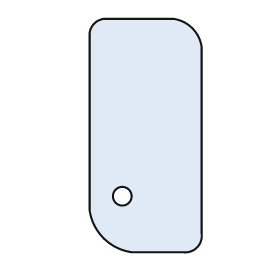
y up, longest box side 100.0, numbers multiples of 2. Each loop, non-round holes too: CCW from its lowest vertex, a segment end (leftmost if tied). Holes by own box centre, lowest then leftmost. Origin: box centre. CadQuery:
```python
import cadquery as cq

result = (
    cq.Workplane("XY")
    .moveTo(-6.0, -50.0)
    .lineTo(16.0, -50.0)
    .threePointArc((22.0, -48.0), (24.0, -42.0))
    .lineTo(24.0, 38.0)
    .threePointArc((20.0, 46.0), (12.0, 50.0))
    .lineTo(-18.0, 50.0)
    .threePointArc((-22.0, 48.0), (-24.0, 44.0))
    .lineTo(-24.0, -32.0)
    .threePointArc((-18.0, -44.0), (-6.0, -50.0))
    .close()
    .moveTo(-10.0, -26.0)
    .circle(4.0)
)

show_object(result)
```